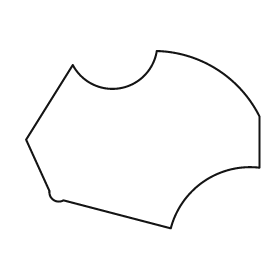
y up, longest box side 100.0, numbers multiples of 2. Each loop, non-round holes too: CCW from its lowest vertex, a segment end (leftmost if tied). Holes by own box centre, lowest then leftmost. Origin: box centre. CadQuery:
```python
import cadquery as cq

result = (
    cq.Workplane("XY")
    .moveTo(12.0, -38.0)
    .threePointArc((26.0, -18.0), (50.0, -12.0))
    .lineTo(50.0, 10.0)
    .threePointArc((32.0, 30.0), (6.0, 38.0))
    .threePointArc((-10.0, 22.0), (-30.0, 32.0))
    .lineTo(-50.0, 0.0)
    .lineTo(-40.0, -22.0)
    .threePointArc((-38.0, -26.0), (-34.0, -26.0))
    .close()
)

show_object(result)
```